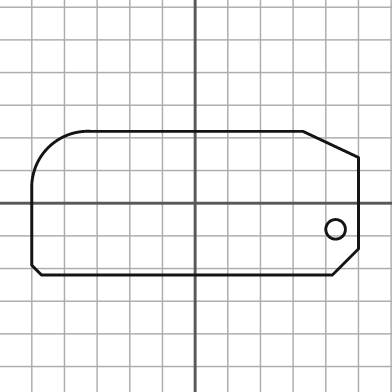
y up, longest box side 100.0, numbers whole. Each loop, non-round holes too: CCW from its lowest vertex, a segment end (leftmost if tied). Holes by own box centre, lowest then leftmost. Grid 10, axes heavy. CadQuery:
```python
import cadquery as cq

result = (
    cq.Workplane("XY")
    .moveTo(-47.0, -22.0)
    .lineTo(42.0, -22.0)
    .lineTo(50.0, -14.0)
    .lineTo(50.0, 14.0)
    .lineTo(33.0, 22.0)
    .lineTo(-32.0, 22.0)
    .threePointArc((-45.0, 17.0), (-50.0, 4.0))
    .lineTo(-50.0, -19.0)
    .close()
    .moveTo(43.0, -8.0)
    .circle(3.0)
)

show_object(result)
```